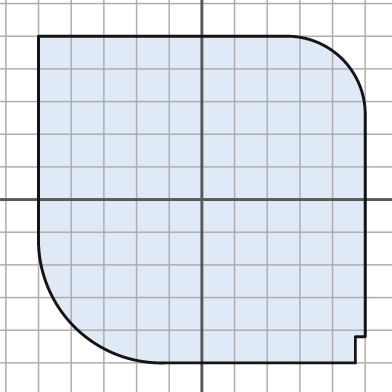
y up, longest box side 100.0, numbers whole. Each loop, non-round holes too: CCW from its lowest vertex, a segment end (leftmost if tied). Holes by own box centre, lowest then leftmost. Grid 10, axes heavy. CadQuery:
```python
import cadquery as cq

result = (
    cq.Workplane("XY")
    .moveTo(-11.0, -50.0)
    .lineTo(47.0, -50.0)
    .lineTo(47.0, -42.0)
    .lineTo(50.0, -42.0)
    .lineTo(50.0, 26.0)
    .threePointArc((43.0, 43.0), (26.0, 50.0))
    .lineTo(-50.0, 50.0)
    .lineTo(-50.0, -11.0)
    .threePointArc((-39.0, -39.0), (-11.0, -50.0))
    .close()
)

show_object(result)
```